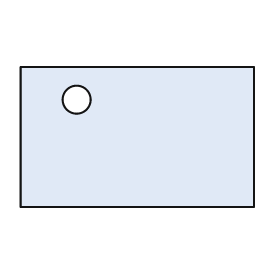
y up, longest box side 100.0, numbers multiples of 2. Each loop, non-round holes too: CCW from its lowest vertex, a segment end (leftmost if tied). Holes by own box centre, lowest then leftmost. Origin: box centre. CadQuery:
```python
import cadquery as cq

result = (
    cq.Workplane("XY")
    .moveTo(-50.0, -30.0)
    .lineTo(50.0, -30.0)
    .lineTo(50.0, 30.0)
    .lineTo(-50.0, 30.0)
    .close()
    .moveTo(-26.0, 16.0)
    .circle(6.0)
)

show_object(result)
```